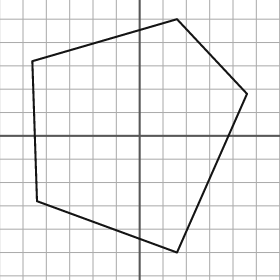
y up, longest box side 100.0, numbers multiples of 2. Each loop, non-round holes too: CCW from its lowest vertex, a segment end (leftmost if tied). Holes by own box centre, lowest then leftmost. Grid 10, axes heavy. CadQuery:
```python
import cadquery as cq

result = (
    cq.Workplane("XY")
    .moveTo(16.0, -50.0)
    .lineTo(46.0, 18.0)
    .lineTo(16.0, 50.0)
    .lineTo(-46.0, 32.0)
    .lineTo(-44.0, -28.0)
    .close()
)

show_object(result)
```